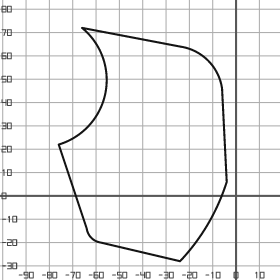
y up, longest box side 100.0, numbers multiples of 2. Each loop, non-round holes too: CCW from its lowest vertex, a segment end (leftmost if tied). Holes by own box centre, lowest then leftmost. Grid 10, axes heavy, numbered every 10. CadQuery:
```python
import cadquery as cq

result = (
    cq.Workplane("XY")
    .moveTo(-24.0, -28.0)
    .threePointArc((-12.0, -12.0), (-4.0, 6.0))
    .lineTo(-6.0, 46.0)
    .threePointArc((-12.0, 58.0), (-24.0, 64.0))
    .lineTo(-66.0, 72.0)
    .threePointArc((-56.0, 44.0), (-76.0, 22.0))
    .lineTo(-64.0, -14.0)
    .threePointArc((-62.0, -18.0), (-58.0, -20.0))
    .close()
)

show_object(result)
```